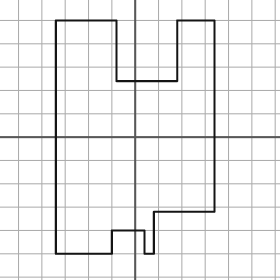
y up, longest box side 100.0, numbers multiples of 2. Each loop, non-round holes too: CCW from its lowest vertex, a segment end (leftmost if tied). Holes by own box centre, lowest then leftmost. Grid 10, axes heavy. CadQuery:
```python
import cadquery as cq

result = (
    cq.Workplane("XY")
    .moveTo(-34.0, -50.0)
    .lineTo(-10.0, -50.0)
    .lineTo(-10.0, -40.0)
    .lineTo(4.0, -40.0)
    .lineTo(4.0, -50.0)
    .lineTo(8.0, -50.0)
    .lineTo(8.0, -32.0)
    .lineTo(34.0, -32.0)
    .lineTo(34.0, 50.0)
    .lineTo(18.0, 50.0)
    .lineTo(18.0, 24.0)
    .lineTo(-8.0, 24.0)
    .lineTo(-8.0, 50.0)
    .lineTo(-34.0, 50.0)
    .close()
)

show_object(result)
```